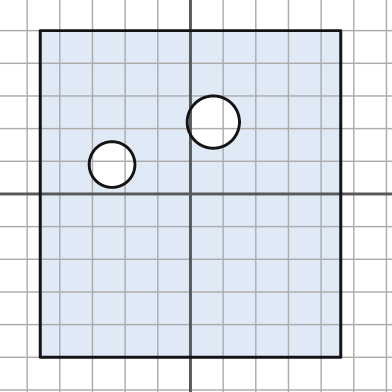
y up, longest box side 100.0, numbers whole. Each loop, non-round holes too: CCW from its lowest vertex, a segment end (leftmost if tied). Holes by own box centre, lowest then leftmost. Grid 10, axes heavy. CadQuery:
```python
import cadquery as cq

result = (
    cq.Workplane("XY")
    .moveTo(-46.0, -50.0)
    .lineTo(46.0, -50.0)
    .lineTo(46.0, 50.0)
    .lineTo(-46.0, 50.0)
    .close()
    .moveTo(-24.0, 9.0)
    .circle(7.0)
    .moveTo(7.0, 22.0)
    .circle(8.0)
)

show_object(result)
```